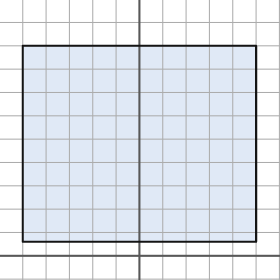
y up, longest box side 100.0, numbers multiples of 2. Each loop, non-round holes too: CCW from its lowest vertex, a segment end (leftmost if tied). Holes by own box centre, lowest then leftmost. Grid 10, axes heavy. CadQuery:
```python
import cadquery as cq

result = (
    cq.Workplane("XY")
    .moveTo(-50.0, 6.0)
    .lineTo(50.0, 6.0)
    .lineTo(50.0, 90.0)
    .lineTo(-50.0, 90.0)
    .close()
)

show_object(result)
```